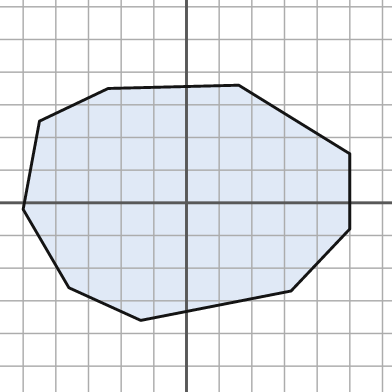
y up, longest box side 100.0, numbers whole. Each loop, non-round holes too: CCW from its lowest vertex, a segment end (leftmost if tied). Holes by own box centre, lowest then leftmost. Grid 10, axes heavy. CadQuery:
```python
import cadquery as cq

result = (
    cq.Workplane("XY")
    .moveTo(-14.0, -36.0)
    .lineTo(32.0, -27.0)
    .lineTo(50.0, -8.0)
    .lineTo(50.0, 15.0)
    .lineTo(16.0, 36.0)
    .lineTo(-24.0, 35.0)
    .lineTo(-45.0, 25.0)
    .lineTo(-50.0, -2.0)
    .lineTo(-36.0, -26.0)
    .close()
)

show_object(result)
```